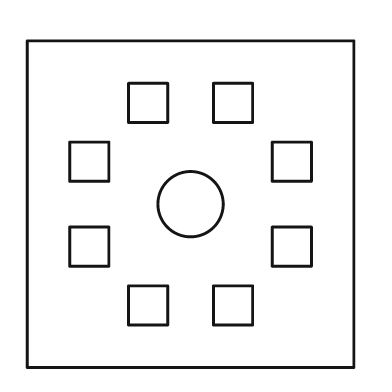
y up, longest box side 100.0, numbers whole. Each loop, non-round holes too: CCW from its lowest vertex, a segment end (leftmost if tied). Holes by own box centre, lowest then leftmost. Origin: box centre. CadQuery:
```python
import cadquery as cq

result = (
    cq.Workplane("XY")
    .moveTo(-50.0, -50.0)
    .lineTo(50.0, -50.0)
    .lineTo(50.0, 50.0)
    .lineTo(-50.0, 50.0)
    .close()
    .moveTo(-19.0, -37.0)
    .lineTo(-7.0, -37.0)
    .lineTo(-7.0, -25.0)
    .lineTo(-19.0, -25.0)
    .close()
    .moveTo(7.0, -37.0)
    .lineTo(19.0, -37.0)
    .lineTo(19.0, -25.0)
    .lineTo(7.0, -25.0)
    .close()
    .moveTo(-37.0, -19.0)
    .lineTo(-25.0, -19.0)
    .lineTo(-25.0, -7.0)
    .lineTo(-37.0, -7.0)
    .close()
    .moveTo(25.0, -19.0)
    .lineTo(37.0, -19.0)
    .lineTo(37.0, -7.0)
    .lineTo(25.0, -7.0)
    .close()
    .moveTo(0.0, 0.0)
    .circle(10.0)
    .moveTo(-37.0, 7.0)
    .lineTo(-25.0, 7.0)
    .lineTo(-25.0, 19.0)
    .lineTo(-37.0, 19.0)
    .close()
    .moveTo(25.0, 7.0)
    .lineTo(37.0, 7.0)
    .lineTo(37.0, 19.0)
    .lineTo(25.0, 19.0)
    .close()
    .moveTo(-19.0, 25.0)
    .lineTo(-7.0, 25.0)
    .lineTo(-7.0, 37.0)
    .lineTo(-19.0, 37.0)
    .close()
    .moveTo(7.0, 25.0)
    .lineTo(19.0, 25.0)
    .lineTo(19.0, 37.0)
    .lineTo(7.0, 37.0)
    .close()
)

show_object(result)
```